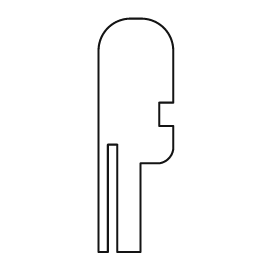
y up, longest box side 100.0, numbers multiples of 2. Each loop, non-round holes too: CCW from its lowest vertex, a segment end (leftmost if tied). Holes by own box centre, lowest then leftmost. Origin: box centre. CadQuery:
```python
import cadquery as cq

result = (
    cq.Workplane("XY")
    .moveTo(-16.0, -50.0)
    .lineTo(-12.0, -50.0)
    .lineTo(-12.0, -4.0)
    .lineTo(-8.0, -4.0)
    .lineTo(-8.0, -50.0)
    .lineTo(2.0, -50.0)
    .lineTo(2.0, -12.0)
    .lineTo(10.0, -12.0)
    .threePointArc((14.0, -10.0), (16.0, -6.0))
    .lineTo(16.0, 4.0)
    .lineTo(10.0, 4.0)
    .lineTo(10.0, 14.0)
    .lineTo(16.0, 14.0)
    .lineTo(16.0, 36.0)
    .threePointArc((12.0, 46.0), (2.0, 50.0))
    .lineTo(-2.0, 50.0)
    .threePointArc((-12.0, 46.0), (-16.0, 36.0))
    .close()
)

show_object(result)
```